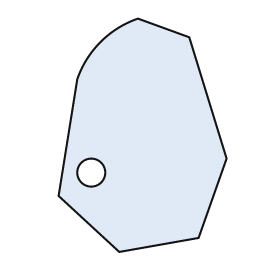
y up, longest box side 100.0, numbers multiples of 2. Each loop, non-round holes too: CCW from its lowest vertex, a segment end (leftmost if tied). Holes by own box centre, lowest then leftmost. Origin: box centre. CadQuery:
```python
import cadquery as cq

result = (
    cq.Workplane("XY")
    .moveTo(-10.0, -50.0)
    .lineTo(24.0, -44.0)
    .lineTo(36.0, -10.0)
    .lineTo(20.0, 42.0)
    .lineTo(-2.0, 50.0)
    .threePointArc((-18.0, 40.0), (-28.0, 24.0))
    .lineTo(-36.0, -26.0)
    .close()
    .moveTo(-22.0, -16.0)
    .circle(6.0)
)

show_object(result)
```